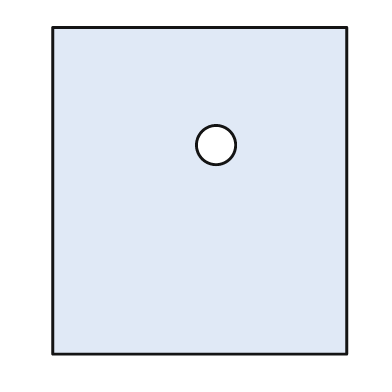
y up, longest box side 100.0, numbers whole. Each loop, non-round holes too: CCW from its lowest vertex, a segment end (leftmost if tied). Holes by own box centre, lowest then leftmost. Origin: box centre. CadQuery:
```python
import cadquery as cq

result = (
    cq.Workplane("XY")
    .moveTo(-45.0, -50.0)
    .lineTo(45.0, -50.0)
    .lineTo(45.0, 50.0)
    .lineTo(-45.0, 50.0)
    .close()
    .moveTo(5.0, 14.0)
    .circle(6.0)
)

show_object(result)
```